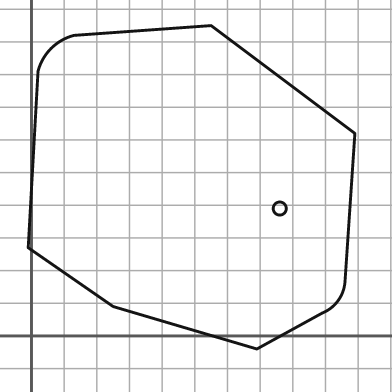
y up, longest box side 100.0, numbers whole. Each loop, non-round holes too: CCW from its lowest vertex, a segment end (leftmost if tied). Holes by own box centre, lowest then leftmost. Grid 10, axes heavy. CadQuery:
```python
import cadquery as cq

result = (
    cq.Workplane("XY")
    .moveTo(69.0, -4.0)
    .lineTo(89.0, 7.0)
    .threePointArc((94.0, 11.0), (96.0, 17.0))
    .lineTo(99.0, 62.0)
    .lineTo(55.0, 95.0)
    .lineTo(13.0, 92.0)
    .threePointArc((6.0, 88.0), (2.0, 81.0))
    .lineTo(-1.0, 27.0)
    .lineTo(25.0, 9.0)
    .close()
    .moveTo(76.0, 39.0)
    .circle(2.0)
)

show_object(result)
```